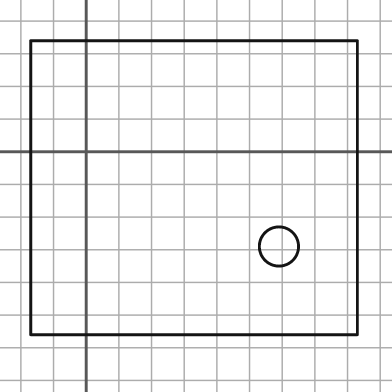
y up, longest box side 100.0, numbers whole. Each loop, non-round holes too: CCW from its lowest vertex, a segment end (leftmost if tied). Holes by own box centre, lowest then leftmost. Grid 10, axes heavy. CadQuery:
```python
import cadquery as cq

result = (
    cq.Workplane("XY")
    .moveTo(-17.0, -56.0)
    .lineTo(83.0, -56.0)
    .lineTo(83.0, 34.0)
    .lineTo(-17.0, 34.0)
    .close()
    .moveTo(59.0, -29.0)
    .circle(6.0)
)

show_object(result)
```